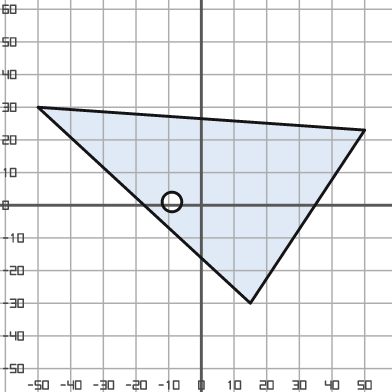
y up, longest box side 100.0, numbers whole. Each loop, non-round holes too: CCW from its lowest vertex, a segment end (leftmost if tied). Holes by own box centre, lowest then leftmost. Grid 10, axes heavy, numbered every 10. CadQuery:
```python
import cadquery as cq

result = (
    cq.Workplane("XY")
    .moveTo(15.0, -30.0)
    .lineTo(50.0, 23.0)
    .lineTo(-50.0, 30.0)
    .close()
    .moveTo(-9.0, 1.0)
    .circle(3.0)
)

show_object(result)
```